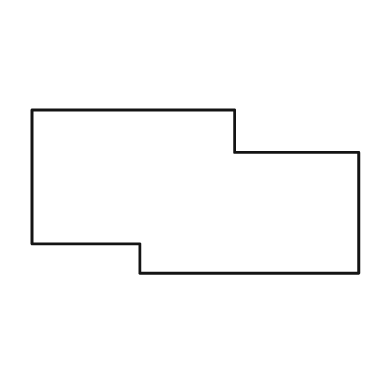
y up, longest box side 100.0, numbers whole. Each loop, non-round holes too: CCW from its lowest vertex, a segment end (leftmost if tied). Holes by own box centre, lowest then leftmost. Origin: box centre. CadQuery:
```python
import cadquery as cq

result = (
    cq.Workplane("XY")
    .moveTo(-17.0, -25.0)
    .lineTo(50.0, -25.0)
    .lineTo(50.0, 12.0)
    .lineTo(12.0, 12.0)
    .lineTo(12.0, 25.0)
    .lineTo(-50.0, 25.0)
    .lineTo(-50.0, -16.0)
    .lineTo(-17.0, -16.0)
    .close()
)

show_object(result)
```